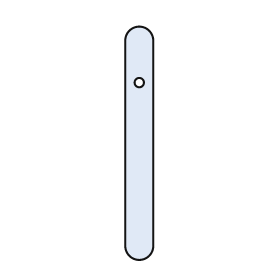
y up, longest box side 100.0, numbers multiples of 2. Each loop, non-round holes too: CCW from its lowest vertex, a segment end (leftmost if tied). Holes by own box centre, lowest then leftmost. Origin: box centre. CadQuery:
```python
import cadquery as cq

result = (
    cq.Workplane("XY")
    .moveTo(-6.0, -44.0)
    .threePointArc((0.0, -50.0), (6.0, -44.0))
    .lineTo(6.0, 44.0)
    .threePointArc((0.0, 50.0), (-6.0, 44.0))
    .close()
    .moveTo(0.0, 26.0)
    .circle(2.0)
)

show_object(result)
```